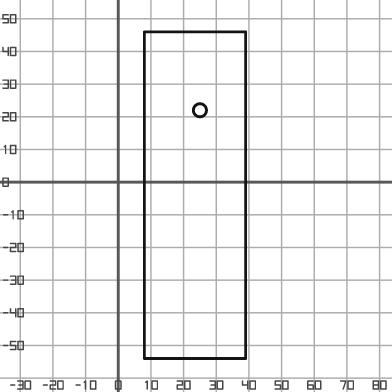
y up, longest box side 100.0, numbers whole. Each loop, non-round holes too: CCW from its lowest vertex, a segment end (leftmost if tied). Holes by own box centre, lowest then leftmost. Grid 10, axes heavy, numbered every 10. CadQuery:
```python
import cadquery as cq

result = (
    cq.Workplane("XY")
    .moveTo(8.0, -54.0)
    .lineTo(39.0, -54.0)
    .lineTo(39.0, 46.0)
    .lineTo(8.0, 46.0)
    .close()
    .moveTo(25.0, 22.0)
    .circle(2.0)
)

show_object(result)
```